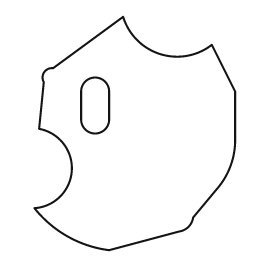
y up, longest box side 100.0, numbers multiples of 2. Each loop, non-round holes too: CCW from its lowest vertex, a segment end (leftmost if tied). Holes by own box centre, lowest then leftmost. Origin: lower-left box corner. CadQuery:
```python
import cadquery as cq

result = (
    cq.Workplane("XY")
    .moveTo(32.0, 0.0)
    .lineTo(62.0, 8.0)
    .threePointArc((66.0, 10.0), (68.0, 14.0))
    .lineTo(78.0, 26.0)
    .threePointArc((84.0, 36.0), (86.0, 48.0))
    .lineTo(86.0, 68.0)
    .lineTo(76.0, 88.0)
    .threePointArc((54.0, 84.0), (38.0, 100.0))
    .lineTo(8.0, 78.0)
    .threePointArc((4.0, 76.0), (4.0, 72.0))
    .lineTo(2.0, 52.0)
    .threePointArc((16.0, 34.0), (0.0, 18.0))
    .threePointArc((14.0, 6.0), (32.0, 0.0))
    .close()
    .moveTo(20.0, 56.0)
    .threePointArc((26.0, 50.0), (32.0, 56.0))
    .lineTo(32.0, 68.0)
    .threePointArc((26.0, 74.0), (20.0, 68.0))
    .close()
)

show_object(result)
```